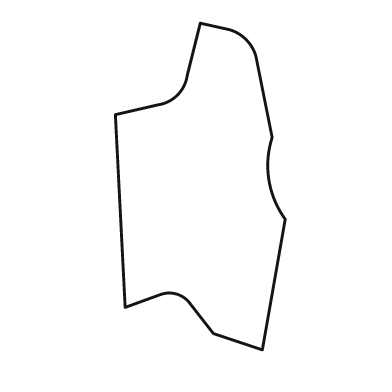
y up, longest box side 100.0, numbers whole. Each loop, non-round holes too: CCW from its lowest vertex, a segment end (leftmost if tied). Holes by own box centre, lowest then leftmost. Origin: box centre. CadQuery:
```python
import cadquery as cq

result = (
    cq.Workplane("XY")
    .moveTo(19.0, -50.0)
    .lineTo(26.0, -10.0)
    .threePointArc((21.0, 2.0), (22.0, 15.0))
    .lineTo(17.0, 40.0)
    .threePointArc((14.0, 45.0), (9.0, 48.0))
    .lineTo(0.0, 50.0)
    .lineTo(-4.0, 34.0)
    .threePointArc((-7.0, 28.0), (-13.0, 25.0))
    .lineTo(-26.0, 22.0)
    .lineTo(-23.0, -37.0)
    .lineTo(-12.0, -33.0)
    .threePointArc((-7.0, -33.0), (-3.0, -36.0))
    .lineTo(4.0, -45.0)
    .close()
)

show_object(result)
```